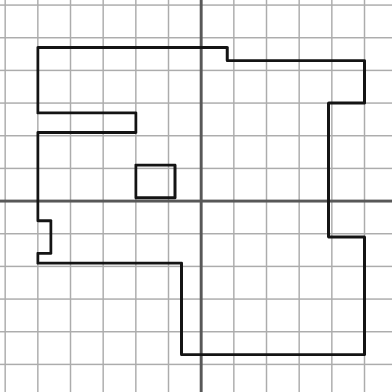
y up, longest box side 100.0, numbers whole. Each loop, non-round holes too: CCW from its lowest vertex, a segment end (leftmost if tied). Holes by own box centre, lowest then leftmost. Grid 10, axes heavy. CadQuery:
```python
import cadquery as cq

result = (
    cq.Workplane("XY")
    .moveTo(-6.0, -47.0)
    .lineTo(50.0, -47.0)
    .lineTo(50.0, -11.0)
    .lineTo(39.0, -11.0)
    .lineTo(39.0, 30.0)
    .lineTo(50.0, 30.0)
    .lineTo(50.0, 43.0)
    .lineTo(8.0, 43.0)
    .lineTo(8.0, 47.0)
    .lineTo(-50.0, 47.0)
    .lineTo(-50.0, 27.0)
    .lineTo(-20.0, 27.0)
    .lineTo(-20.0, 21.0)
    .lineTo(-50.0, 21.0)
    .lineTo(-50.0, -6.0)
    .lineTo(-46.0, -6.0)
    .lineTo(-46.0, -16.0)
    .lineTo(-50.0, -16.0)
    .lineTo(-50.0, -19.0)
    .lineTo(-6.0, -19.0)
    .close()
    .moveTo(-20.0, 1.0)
    .lineTo(-8.0, 1.0)
    .lineTo(-8.0, 11.0)
    .lineTo(-20.0, 11.0)
    .close()
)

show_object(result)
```